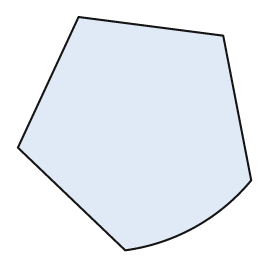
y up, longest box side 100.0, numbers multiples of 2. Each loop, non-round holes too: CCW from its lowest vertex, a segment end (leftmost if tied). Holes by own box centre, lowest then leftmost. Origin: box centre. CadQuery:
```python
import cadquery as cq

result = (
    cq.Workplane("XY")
    .moveTo(-4.0, -50.0)
    .threePointArc((26.0, -40.0), (50.0, -20.0))
    .lineTo(38.0, 42.0)
    .lineTo(-24.0, 50.0)
    .lineTo(-50.0, -6.0)
    .close()
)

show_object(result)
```